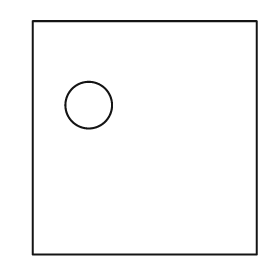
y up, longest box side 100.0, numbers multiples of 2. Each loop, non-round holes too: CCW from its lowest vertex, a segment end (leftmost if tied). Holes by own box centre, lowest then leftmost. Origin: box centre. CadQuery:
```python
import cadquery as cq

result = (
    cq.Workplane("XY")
    .moveTo(-48.0, -50.0)
    .lineTo(48.0, -50.0)
    .lineTo(48.0, 50.0)
    .lineTo(-48.0, 50.0)
    .close()
    .moveTo(-24.0, 14.0)
    .circle(10.0)
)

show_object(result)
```